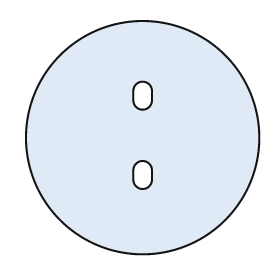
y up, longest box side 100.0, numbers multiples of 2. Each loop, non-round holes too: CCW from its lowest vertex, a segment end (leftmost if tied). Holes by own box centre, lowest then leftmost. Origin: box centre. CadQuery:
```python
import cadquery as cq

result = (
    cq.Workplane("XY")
    .moveTo(0.0, 0.0)
    .circle(50.0)
    .moveTo(-4.0, -18.0)
    .threePointArc((0.0, -22.0), (4.0, -18.0))
    .lineTo(4.0, -14.0)
    .threePointArc((0.0, -10.0), (-4.0, -14.0))
    .close()
    .moveTo(-4.0, 16.0)
    .threePointArc((0.0, 12.0), (4.0, 16.0))
    .lineTo(4.0, 20.0)
    .threePointArc((0.0, 24.0), (-4.0, 20.0))
    .close()
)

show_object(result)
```